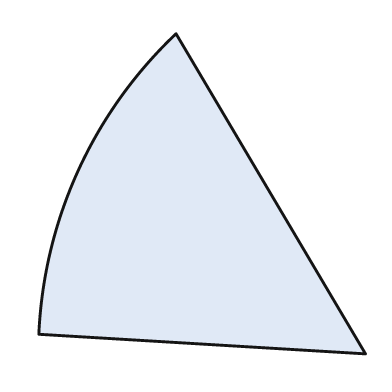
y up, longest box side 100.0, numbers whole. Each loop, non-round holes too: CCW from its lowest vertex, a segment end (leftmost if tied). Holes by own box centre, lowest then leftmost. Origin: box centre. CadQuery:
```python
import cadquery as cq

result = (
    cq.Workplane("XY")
    .moveTo(50.0, -49.0)
    .lineTo(-8.0, 49.0)
    .threePointArc((-38.0, 7.0), (-50.0, -43.0))
    .close()
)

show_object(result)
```